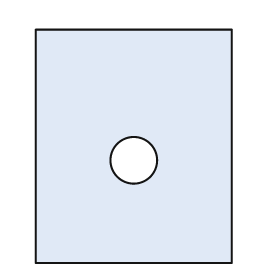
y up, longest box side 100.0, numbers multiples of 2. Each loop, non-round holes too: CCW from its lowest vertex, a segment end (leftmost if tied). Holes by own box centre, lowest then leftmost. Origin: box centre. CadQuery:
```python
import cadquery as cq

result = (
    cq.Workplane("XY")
    .moveTo(-42.0, -50.0)
    .lineTo(42.0, -50.0)
    .lineTo(42.0, 50.0)
    .lineTo(-42.0, 50.0)
    .close()
    .moveTo(0.0, -6.0)
    .circle(10.0)
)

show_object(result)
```